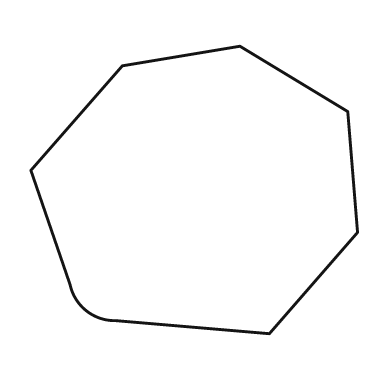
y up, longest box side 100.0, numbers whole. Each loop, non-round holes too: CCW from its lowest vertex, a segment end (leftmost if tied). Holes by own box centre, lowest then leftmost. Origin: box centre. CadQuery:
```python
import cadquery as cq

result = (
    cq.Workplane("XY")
    .moveTo(23.0, -44.0)
    .lineTo(50.0, -13.0)
    .lineTo(47.0, 24.0)
    .lineTo(14.0, 44.0)
    .lineTo(-22.0, 38.0)
    .lineTo(-50.0, 6.0)
    .lineTo(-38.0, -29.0)
    .threePointArc((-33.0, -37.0), (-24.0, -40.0))
    .close()
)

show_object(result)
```